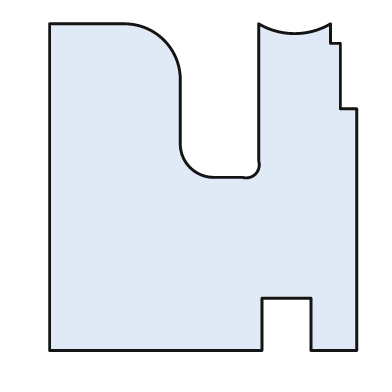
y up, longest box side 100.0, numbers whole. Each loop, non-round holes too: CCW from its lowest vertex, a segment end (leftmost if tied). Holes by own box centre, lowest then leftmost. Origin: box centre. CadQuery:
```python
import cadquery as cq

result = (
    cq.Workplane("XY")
    .moveTo(-47.0, -50.0)
    .lineTo(18.0, -50.0)
    .lineTo(18.0, -34.0)
    .lineTo(33.0, -34.0)
    .lineTo(33.0, -50.0)
    .lineTo(47.0, -50.0)
    .lineTo(47.0, 24.0)
    .lineTo(42.0, 24.0)
    .lineTo(42.0, 44.0)
    .lineTo(39.0, 44.0)
    .lineTo(39.0, 50.0)
    .threePointArc((28.0, 47.0), (17.0, 50.0))
    .lineTo(17.0, 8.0)
    .threePointArc((16.0, 4.0), (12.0, 3.0))
    .lineTo(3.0, 3.0)
    .threePointArc((-4.0, 6.0), (-7.0, 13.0))
    .lineTo(-7.0, 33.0)
    .threePointArc((-12.0, 45.0), (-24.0, 50.0))
    .lineTo(-47.0, 50.0)
    .close()
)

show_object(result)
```